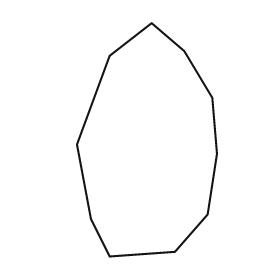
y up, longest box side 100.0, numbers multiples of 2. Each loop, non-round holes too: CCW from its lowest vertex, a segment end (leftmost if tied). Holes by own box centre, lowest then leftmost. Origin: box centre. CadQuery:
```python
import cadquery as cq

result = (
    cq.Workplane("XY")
    .moveTo(-16.0, -50.0)
    .lineTo(12.0, -48.0)
    .lineTo(26.0, -32.0)
    .lineTo(30.0, -6.0)
    .lineTo(28.0, 18.0)
    .lineTo(16.0, 38.0)
    .lineTo(2.0, 50.0)
    .lineTo(-16.0, 36.0)
    .lineTo(-30.0, -2.0)
    .lineTo(-24.0, -34.0)
    .close()
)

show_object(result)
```